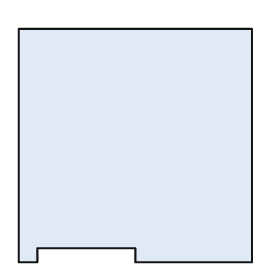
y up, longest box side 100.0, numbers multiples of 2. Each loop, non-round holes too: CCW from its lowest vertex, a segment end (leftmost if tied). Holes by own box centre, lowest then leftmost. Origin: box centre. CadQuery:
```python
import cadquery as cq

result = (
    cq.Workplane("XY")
    .moveTo(-50.0, -50.0)
    .lineTo(-42.0, -50.0)
    .lineTo(-42.0, -44.0)
    .lineTo(0.0, -44.0)
    .lineTo(0.0, -50.0)
    .lineTo(50.0, -50.0)
    .lineTo(50.0, 50.0)
    .lineTo(-50.0, 50.0)
    .close()
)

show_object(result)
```